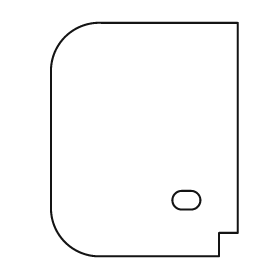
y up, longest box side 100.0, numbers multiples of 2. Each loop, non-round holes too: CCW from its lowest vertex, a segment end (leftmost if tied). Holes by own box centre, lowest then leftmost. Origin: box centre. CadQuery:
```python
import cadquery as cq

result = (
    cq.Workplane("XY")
    .moveTo(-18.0, -50.0)
    .lineTo(32.0, -50.0)
    .lineTo(32.0, -40.0)
    .lineTo(40.0, -40.0)
    .lineTo(40.0, 50.0)
    .lineTo(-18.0, 50.0)
    .threePointArc((-34.0, 44.0), (-40.0, 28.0))
    .lineTo(-40.0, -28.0)
    .threePointArc((-34.0, -44.0), (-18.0, -50.0))
    .close()
    .moveTo(16.0, -30.0)
    .lineTo(20.0, -30.0)
    .threePointArc((24.0, -26.0), (20.0, -22.0))
    .lineTo(16.0, -22.0)
    .threePointArc((12.0, -26.0), (16.0, -30.0))
    .close()
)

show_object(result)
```